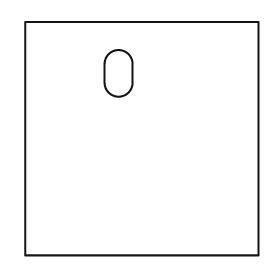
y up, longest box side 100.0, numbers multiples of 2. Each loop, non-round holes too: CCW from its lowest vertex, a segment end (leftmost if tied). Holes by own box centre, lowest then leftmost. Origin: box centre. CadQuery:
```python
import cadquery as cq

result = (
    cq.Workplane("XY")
    .moveTo(-50.0, -50.0)
    .lineTo(50.0, -50.0)
    .lineTo(50.0, 50.0)
    .lineTo(-50.0, 50.0)
    .close()
    .moveTo(-16.0, 24.0)
    .threePointArc((-10.0, 18.0), (-4.0, 24.0))
    .lineTo(-4.0, 32.0)
    .threePointArc((-10.0, 38.0), (-16.0, 32.0))
    .close()
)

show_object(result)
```